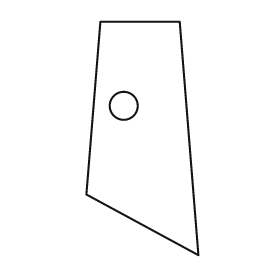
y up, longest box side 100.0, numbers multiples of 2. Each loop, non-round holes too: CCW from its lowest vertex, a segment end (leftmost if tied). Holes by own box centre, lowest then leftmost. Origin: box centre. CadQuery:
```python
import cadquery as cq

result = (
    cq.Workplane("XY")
    .moveTo(24.0, -50.0)
    .lineTo(16.0, 50.0)
    .lineTo(-18.0, 50.0)
    .lineTo(-24.0, -24.0)
    .close()
    .moveTo(-8.0, 14.0)
    .circle(6.0)
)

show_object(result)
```